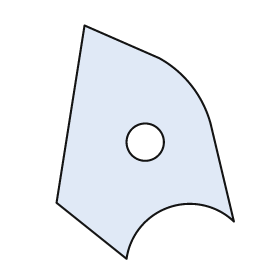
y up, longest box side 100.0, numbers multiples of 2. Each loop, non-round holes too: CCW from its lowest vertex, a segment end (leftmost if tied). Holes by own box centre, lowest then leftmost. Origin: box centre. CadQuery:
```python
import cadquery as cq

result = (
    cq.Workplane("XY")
    .moveTo(-8.0, -50.0)
    .threePointArc((10.0, -28.0), (38.0, -34.0))
    .lineTo(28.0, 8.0)
    .threePointArc((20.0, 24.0), (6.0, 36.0))
    .lineTo(-26.0, 50.0)
    .lineTo(-38.0, -26.0)
    .close()
    .moveTo(0.0, 0.0)
    .circle(8.0)
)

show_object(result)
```